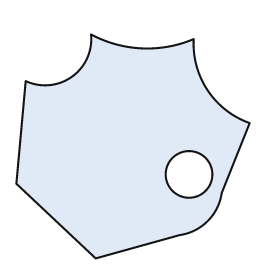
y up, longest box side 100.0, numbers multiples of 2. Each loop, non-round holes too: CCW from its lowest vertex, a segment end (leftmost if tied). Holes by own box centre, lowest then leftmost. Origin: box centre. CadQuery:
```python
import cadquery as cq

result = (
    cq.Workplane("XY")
    .moveTo(-16.0, -48.0)
    .lineTo(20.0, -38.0)
    .threePointArc((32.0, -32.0), (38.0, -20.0))
    .lineTo(50.0, 10.0)
    .threePointArc((32.0, 24.0), (26.0, 46.0))
    .threePointArc((4.0, 42.0), (-18.0, 48.0))
    .threePointArc((-26.0, 30.0), (-46.0, 28.0))
    .lineTo(-50.0, -16.0)
    .close()
    .moveTo(24.0, -12.0)
    .circle(10.0)
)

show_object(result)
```